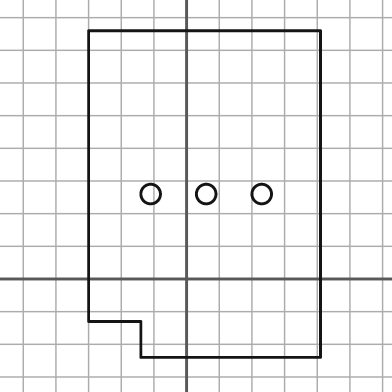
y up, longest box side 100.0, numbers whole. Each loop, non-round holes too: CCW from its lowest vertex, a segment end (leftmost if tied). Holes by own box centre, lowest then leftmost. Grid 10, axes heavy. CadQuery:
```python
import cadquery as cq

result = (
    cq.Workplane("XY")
    .moveTo(-14.0, -24.0)
    .lineTo(41.0, -24.0)
    .lineTo(41.0, 76.0)
    .lineTo(-30.0, 76.0)
    .lineTo(-30.0, -13.0)
    .lineTo(-14.0, -13.0)
    .close()
    .moveTo(-11.0, 26.0)
    .circle(3.0)
    .moveTo(6.0, 26.0)
    .circle(3.0)
    .moveTo(23.0, 26.0)
    .circle(3.0)
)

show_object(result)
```